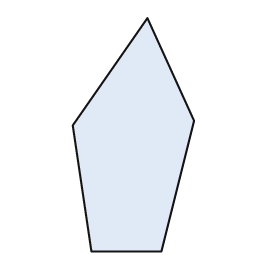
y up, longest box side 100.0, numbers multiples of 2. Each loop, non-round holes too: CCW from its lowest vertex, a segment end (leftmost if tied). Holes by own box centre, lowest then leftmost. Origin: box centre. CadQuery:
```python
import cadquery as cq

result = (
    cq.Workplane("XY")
    .moveTo(-18.0, -50.0)
    .lineTo(12.0, -50.0)
    .lineTo(26.0, 6.0)
    .lineTo(6.0, 50.0)
    .lineTo(-26.0, 4.0)
    .close()
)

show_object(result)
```